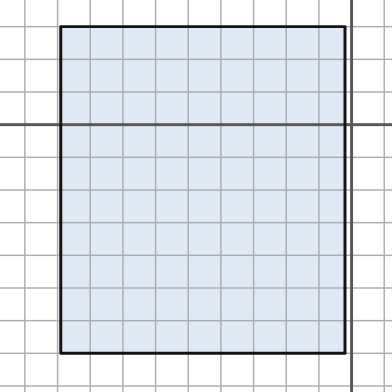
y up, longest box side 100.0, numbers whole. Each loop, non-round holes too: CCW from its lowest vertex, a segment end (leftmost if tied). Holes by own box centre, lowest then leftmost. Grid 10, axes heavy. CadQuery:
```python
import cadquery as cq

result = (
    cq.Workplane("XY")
    .moveTo(-89.0, -70.0)
    .lineTo(-2.0, -70.0)
    .lineTo(-2.0, 30.0)
    .lineTo(-89.0, 30.0)
    .close()
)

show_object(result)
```